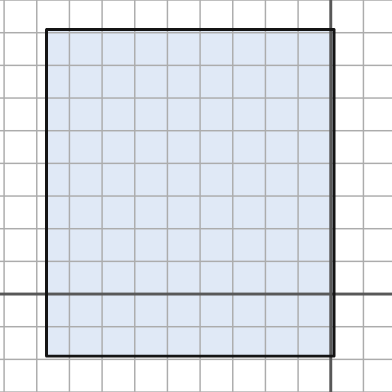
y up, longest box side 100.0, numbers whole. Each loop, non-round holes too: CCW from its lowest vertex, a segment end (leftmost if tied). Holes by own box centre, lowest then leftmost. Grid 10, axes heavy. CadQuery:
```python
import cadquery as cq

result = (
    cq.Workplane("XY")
    .moveTo(-87.0, -19.0)
    .lineTo(1.0, -19.0)
    .lineTo(1.0, 81.0)
    .lineTo(-87.0, 81.0)
    .close()
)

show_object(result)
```